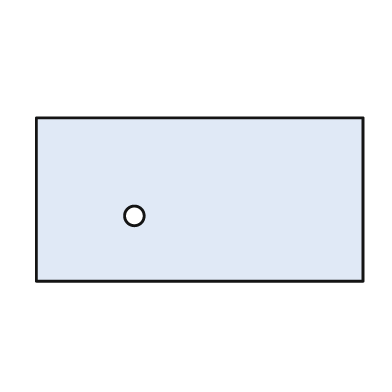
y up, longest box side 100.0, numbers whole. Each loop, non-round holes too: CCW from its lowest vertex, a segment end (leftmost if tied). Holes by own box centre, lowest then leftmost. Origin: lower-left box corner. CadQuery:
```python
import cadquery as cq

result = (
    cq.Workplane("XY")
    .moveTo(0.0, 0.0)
    .lineTo(100.0, 0.0)
    .lineTo(100.0, 50.0)
    .lineTo(0.0, 50.0)
    .close()
    .moveTo(30.0, 20.0)
    .circle(3.0)
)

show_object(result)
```